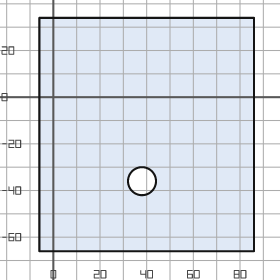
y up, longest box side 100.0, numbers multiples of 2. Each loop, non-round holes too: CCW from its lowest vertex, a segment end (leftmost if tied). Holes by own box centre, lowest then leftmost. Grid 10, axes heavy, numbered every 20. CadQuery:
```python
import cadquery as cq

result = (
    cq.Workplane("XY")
    .moveTo(-6.0, -66.0)
    .lineTo(86.0, -66.0)
    .lineTo(86.0, 34.0)
    .lineTo(-6.0, 34.0)
    .close()
    .moveTo(38.0, -36.0)
    .circle(6.0)
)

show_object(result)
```